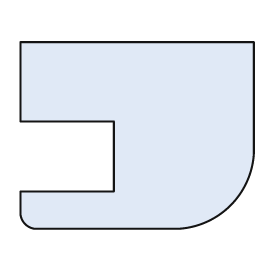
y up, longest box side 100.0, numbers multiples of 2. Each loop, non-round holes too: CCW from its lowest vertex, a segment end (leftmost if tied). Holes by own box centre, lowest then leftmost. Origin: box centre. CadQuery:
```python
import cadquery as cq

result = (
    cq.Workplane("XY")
    .moveTo(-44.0, -40.0)
    .lineTo(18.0, -40.0)
    .threePointArc((40.0, -30.0), (50.0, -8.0))
    .lineTo(50.0, 40.0)
    .lineTo(-50.0, 40.0)
    .lineTo(-50.0, 6.0)
    .lineTo(-10.0, 6.0)
    .lineTo(-10.0, -24.0)
    .lineTo(-50.0, -24.0)
    .lineTo(-50.0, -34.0)
    .threePointArc((-48.0, -38.0), (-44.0, -40.0))
    .close()
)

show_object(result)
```